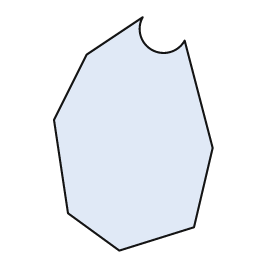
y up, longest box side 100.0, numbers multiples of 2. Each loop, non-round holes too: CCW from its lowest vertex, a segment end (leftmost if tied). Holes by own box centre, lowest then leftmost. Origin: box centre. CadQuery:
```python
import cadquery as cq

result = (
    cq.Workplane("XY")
    .moveTo(-6.0, -50.0)
    .lineTo(26.0, -40.0)
    .lineTo(34.0, -6.0)
    .lineTo(22.0, 40.0)
    .threePointArc((8.0, 36.0), (4.0, 50.0))
    .lineTo(-20.0, 34.0)
    .lineTo(-34.0, 6.0)
    .lineTo(-28.0, -34.0)
    .close()
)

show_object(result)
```